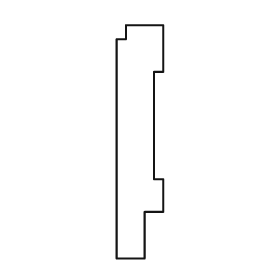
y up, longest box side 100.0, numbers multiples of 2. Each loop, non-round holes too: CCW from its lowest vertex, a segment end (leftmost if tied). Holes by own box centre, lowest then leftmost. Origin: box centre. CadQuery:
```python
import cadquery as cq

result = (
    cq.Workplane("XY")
    .moveTo(-10.0, -50.0)
    .lineTo(2.0, -50.0)
    .lineTo(2.0, -30.0)
    .lineTo(10.0, -30.0)
    .lineTo(10.0, -16.0)
    .lineTo(6.0, -16.0)
    .lineTo(6.0, 30.0)
    .lineTo(10.0, 30.0)
    .lineTo(10.0, 50.0)
    .lineTo(-6.0, 50.0)
    .lineTo(-6.0, 44.0)
    .lineTo(-10.0, 44.0)
    .close()
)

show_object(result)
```